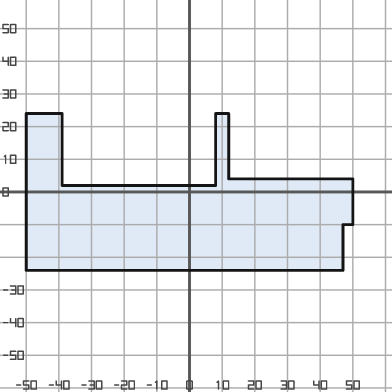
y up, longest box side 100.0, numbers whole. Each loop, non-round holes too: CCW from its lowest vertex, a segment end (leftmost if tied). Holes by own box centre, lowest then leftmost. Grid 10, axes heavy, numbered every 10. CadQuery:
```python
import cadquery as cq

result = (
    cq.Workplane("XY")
    .moveTo(-50.0, -24.0)
    .lineTo(47.0, -24.0)
    .lineTo(47.0, -10.0)
    .lineTo(50.0, -10.0)
    .lineTo(50.0, 4.0)
    .lineTo(12.0, 4.0)
    .lineTo(12.0, 24.0)
    .lineTo(8.0, 24.0)
    .lineTo(8.0, 2.0)
    .lineTo(-39.0, 2.0)
    .lineTo(-39.0, 24.0)
    .lineTo(-50.0, 24.0)
    .close()
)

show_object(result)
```